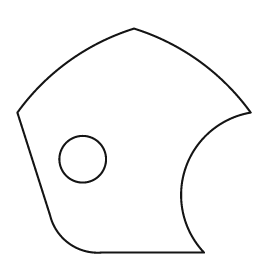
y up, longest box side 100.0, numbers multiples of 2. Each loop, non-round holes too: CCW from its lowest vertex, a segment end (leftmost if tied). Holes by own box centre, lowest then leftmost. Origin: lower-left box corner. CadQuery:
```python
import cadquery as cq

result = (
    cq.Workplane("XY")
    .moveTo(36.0, 0.0)
    .lineTo(80.0, 0.0)
    .threePointArc((72.0, 36.0), (100.0, 60.0))
    .threePointArc((78.0, 82.0), (50.0, 96.0))
    .threePointArc((22.0, 82.0), (0.0, 60.0))
    .lineTo(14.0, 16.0)
    .threePointArc((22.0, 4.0), (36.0, 0.0))
    .close()
    .moveTo(28.0, 40.0)
    .circle(10.0)
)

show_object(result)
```